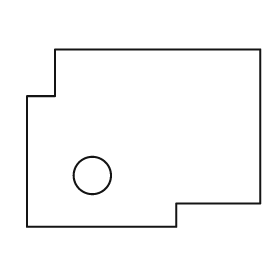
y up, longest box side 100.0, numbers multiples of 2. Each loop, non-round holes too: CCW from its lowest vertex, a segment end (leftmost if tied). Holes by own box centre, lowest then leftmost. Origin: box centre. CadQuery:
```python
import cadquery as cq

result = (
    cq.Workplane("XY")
    .moveTo(-50.0, -38.0)
    .lineTo(14.0, -38.0)
    .lineTo(14.0, -28.0)
    .lineTo(50.0, -28.0)
    .lineTo(50.0, 38.0)
    .lineTo(-38.0, 38.0)
    .lineTo(-38.0, 18.0)
    .lineTo(-50.0, 18.0)
    .close()
    .moveTo(-22.0, -16.0)
    .circle(8.0)
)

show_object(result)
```